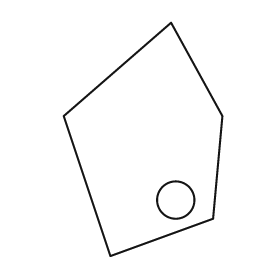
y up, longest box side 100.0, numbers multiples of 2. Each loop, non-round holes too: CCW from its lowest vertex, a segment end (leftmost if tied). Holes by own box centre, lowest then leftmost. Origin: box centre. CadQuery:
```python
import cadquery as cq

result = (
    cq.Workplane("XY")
    .moveTo(-14.0, -50.0)
    .lineTo(30.0, -34.0)
    .lineTo(34.0, 10.0)
    .lineTo(12.0, 50.0)
    .lineTo(-34.0, 10.0)
    .close()
    .moveTo(14.0, -26.0)
    .circle(8.0)
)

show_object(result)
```